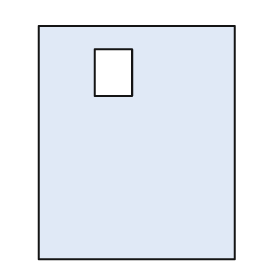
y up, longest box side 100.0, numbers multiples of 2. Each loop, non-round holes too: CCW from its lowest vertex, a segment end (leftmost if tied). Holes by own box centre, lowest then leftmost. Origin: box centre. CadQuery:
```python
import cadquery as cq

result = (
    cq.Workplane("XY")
    .moveTo(-42.0, -50.0)
    .lineTo(42.0, -50.0)
    .lineTo(42.0, 50.0)
    .lineTo(-42.0, 50.0)
    .close()
    .moveTo(-18.0, 20.0)
    .lineTo(-2.0, 20.0)
    .lineTo(-2.0, 40.0)
    .lineTo(-18.0, 40.0)
    .close()
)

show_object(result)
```